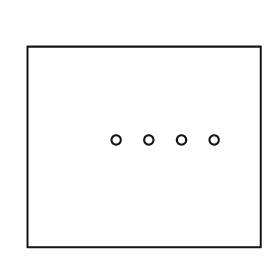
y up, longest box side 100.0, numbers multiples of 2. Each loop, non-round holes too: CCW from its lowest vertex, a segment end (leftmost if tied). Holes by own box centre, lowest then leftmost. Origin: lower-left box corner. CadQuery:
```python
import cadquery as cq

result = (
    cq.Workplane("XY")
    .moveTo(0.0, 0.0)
    .lineTo(100.0, 0.0)
    .lineTo(100.0, 86.0)
    .lineTo(0.0, 86.0)
    .close()
    .moveTo(38.0, 46.0)
    .circle(2.0)
    .moveTo(52.0, 46.0)
    .circle(2.0)
    .moveTo(66.0, 46.0)
    .circle(2.0)
    .moveTo(80.0, 46.0)
    .circle(2.0)
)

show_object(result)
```